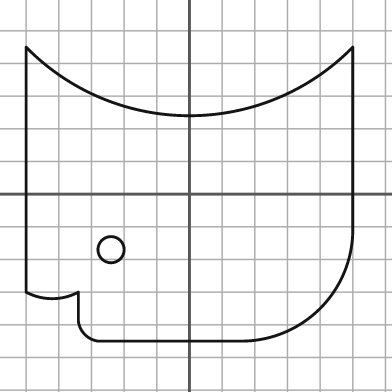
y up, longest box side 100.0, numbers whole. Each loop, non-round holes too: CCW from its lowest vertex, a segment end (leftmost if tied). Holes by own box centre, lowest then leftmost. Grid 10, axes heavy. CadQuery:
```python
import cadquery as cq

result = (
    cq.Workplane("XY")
    .moveTo(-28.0, -45.0)
    .lineTo(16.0, -45.0)
    .threePointArc((40.0, -35.0), (50.0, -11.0))
    .lineTo(50.0, 45.0)
    .threePointArc((0.0, 24.0), (-50.0, 45.0))
    .lineTo(-50.0, -30.0)
    .threePointArc((-42.0, -32.0), (-34.0, -30.0))
    .lineTo(-34.0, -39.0)
    .threePointArc((-32.0, -43.0), (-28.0, -45.0))
    .close()
    .moveTo(-24.0, -17.0)
    .circle(4.0)
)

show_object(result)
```